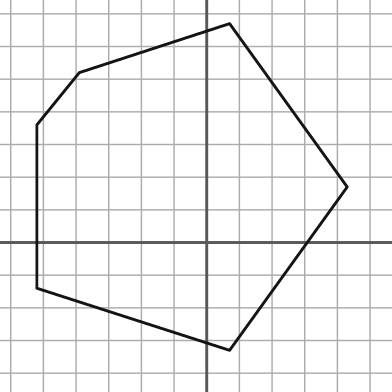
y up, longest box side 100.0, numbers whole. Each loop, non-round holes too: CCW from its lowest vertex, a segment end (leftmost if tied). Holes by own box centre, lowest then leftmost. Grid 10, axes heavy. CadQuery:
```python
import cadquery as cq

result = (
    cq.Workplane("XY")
    .moveTo(7.0, -33.0)
    .lineTo(43.0, 17.0)
    .lineTo(7.0, 67.0)
    .lineTo(-39.0, 52.0)
    .lineTo(-52.0, 36.0)
    .lineTo(-52.0, -14.0)
    .close()
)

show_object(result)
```